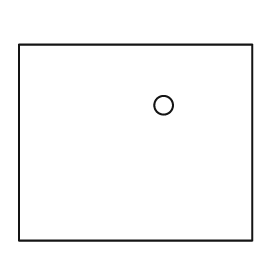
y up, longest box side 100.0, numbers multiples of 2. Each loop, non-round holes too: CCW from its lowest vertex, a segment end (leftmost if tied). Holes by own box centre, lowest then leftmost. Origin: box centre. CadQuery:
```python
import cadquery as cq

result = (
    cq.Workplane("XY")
    .moveTo(-50.0, -42.0)
    .lineTo(50.0, -42.0)
    .lineTo(50.0, 42.0)
    .lineTo(-50.0, 42.0)
    .close()
    .moveTo(12.0, 16.0)
    .circle(4.0)
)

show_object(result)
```